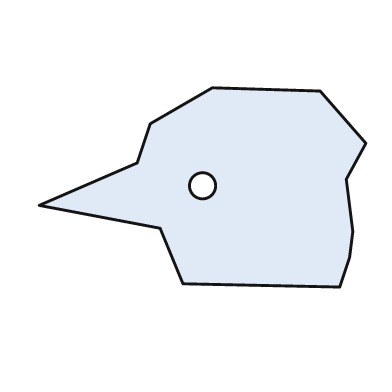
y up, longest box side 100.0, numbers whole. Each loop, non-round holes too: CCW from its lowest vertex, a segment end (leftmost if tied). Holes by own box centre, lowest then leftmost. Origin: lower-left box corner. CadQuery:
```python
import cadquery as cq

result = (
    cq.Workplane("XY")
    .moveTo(92.0, 0.0)
    .lineTo(95.0, 9.0)
    .lineTo(96.0, 17.0)
    .lineTo(94.0, 33.0)
    .lineTo(100.0, 44.0)
    .lineTo(86.0, 60.0)
    .lineTo(53.0, 61.0)
    .lineTo(34.0, 50.0)
    .lineTo(30.0, 38.0)
    .lineTo(0.0, 25.0)
    .lineTo(37.0, 18.0)
    .lineTo(44.0, 1.0)
    .close()
    .moveTo(50.0, 31.0)
    .circle(4.0)
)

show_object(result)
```